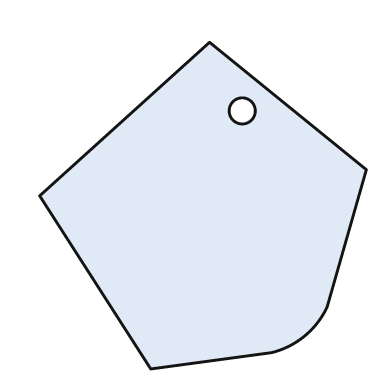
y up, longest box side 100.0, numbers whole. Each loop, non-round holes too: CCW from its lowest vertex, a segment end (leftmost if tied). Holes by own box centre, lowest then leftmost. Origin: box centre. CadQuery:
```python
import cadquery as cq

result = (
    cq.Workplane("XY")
    .moveTo(-16.0, -50.0)
    .lineTo(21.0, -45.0)
    .threePointArc((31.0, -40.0), (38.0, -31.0))
    .lineTo(50.0, 11.0)
    .lineTo(2.0, 50.0)
    .lineTo(-50.0, 3.0)
    .close()
    .moveTo(12.0, 29.0)
    .circle(4.0)
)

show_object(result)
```